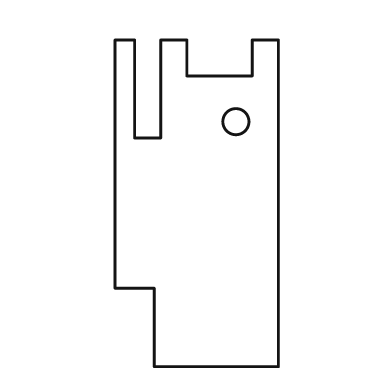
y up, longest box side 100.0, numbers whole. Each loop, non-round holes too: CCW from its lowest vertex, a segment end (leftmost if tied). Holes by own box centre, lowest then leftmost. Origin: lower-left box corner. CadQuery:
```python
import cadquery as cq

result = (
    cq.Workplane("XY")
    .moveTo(12.0, 0.0)
    .lineTo(50.0, 0.0)
    .lineTo(50.0, 100.0)
    .lineTo(42.0, 100.0)
    .lineTo(42.0, 89.0)
    .lineTo(22.0, 89.0)
    .lineTo(22.0, 100.0)
    .lineTo(14.0, 100.0)
    .lineTo(14.0, 70.0)
    .lineTo(6.0, 70.0)
    .lineTo(6.0, 100.0)
    .lineTo(0.0, 100.0)
    .lineTo(0.0, 24.0)
    .lineTo(12.0, 24.0)
    .close()
    .moveTo(37.0, 75.0)
    .circle(4.0)
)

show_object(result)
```